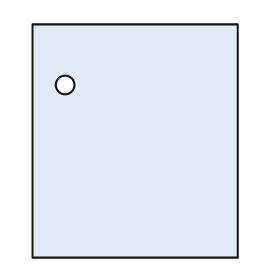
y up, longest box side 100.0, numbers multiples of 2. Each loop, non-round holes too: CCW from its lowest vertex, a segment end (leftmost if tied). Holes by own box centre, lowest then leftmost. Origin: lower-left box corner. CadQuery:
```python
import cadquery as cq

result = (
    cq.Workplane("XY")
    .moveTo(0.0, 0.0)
    .lineTo(88.0, 0.0)
    .lineTo(88.0, 100.0)
    .lineTo(0.0, 100.0)
    .close()
    .moveTo(14.0, 74.0)
    .circle(4.0)
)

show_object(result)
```